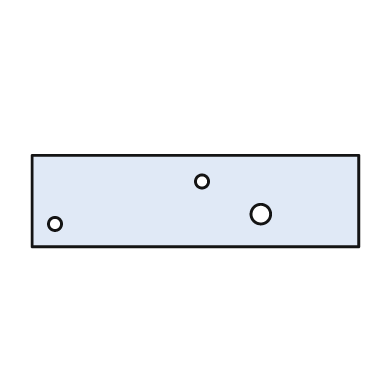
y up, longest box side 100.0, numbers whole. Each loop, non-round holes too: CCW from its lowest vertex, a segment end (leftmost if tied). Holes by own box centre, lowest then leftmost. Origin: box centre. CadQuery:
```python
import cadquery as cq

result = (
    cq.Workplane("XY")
    .moveTo(-50.0, -14.0)
    .lineTo(50.0, -14.0)
    .lineTo(50.0, 14.0)
    .lineTo(-50.0, 14.0)
    .close()
    .moveTo(-43.0, -7.0)
    .circle(2.0)
    .moveTo(20.0, -4.0)
    .circle(3.0)
    .moveTo(2.0, 6.0)
    .circle(2.0)
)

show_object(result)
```